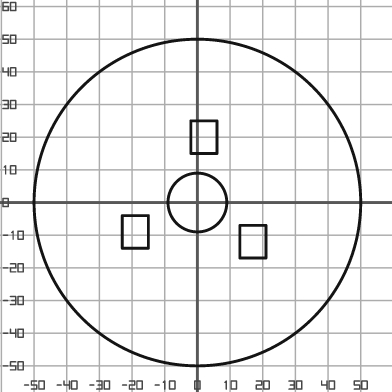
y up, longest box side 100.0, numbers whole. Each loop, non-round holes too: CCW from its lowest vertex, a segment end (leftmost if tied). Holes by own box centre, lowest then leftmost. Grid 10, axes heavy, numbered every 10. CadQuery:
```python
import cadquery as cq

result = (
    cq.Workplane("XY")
    .moveTo(0.0, 0.0)
    .circle(50.0)
    .moveTo(13.0, -17.0)
    .lineTo(21.0, -17.0)
    .lineTo(21.0, -7.0)
    .lineTo(13.0, -7.0)
    .close()
    .moveTo(-23.0, -14.0)
    .lineTo(-15.0, -14.0)
    .lineTo(-15.0, -4.0)
    .lineTo(-23.0, -4.0)
    .close()
    .moveTo(0.0, 0.0)
    .circle(9.0)
    .moveTo(-2.0, 15.0)
    .lineTo(6.0, 15.0)
    .lineTo(6.0, 25.0)
    .lineTo(-2.0, 25.0)
    .close()
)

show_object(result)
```